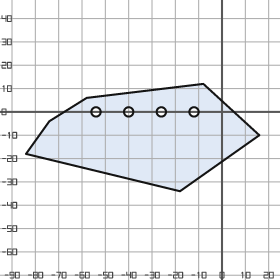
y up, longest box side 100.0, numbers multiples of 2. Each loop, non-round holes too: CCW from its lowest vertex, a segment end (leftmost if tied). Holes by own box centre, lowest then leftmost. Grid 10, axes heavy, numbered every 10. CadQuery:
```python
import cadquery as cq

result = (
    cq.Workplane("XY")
    .moveTo(-18.0, -34.0)
    .lineTo(16.0, -10.0)
    .lineTo(-8.0, 12.0)
    .lineTo(-58.0, 6.0)
    .lineTo(-74.0, -4.0)
    .lineTo(-84.0, -18.0)
    .close()
    .moveTo(-54.0, 0.0)
    .circle(2.0)
    .moveTo(-40.0, 0.0)
    .circle(2.0)
    .moveTo(-26.0, 0.0)
    .circle(2.0)
    .moveTo(-12.0, 0.0)
    .circle(2.0)
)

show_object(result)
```